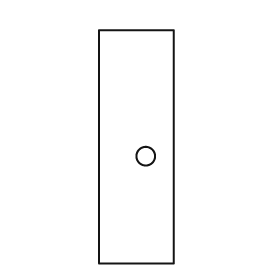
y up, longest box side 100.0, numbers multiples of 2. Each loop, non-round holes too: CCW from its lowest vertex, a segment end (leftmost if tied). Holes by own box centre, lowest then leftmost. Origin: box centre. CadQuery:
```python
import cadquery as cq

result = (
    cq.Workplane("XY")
    .moveTo(-16.0, -50.0)
    .lineTo(16.0, -50.0)
    .lineTo(16.0, 50.0)
    .lineTo(-16.0, 50.0)
    .close()
    .moveTo(4.0, -4.0)
    .circle(4.0)
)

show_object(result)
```